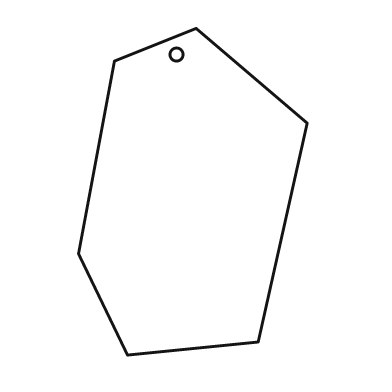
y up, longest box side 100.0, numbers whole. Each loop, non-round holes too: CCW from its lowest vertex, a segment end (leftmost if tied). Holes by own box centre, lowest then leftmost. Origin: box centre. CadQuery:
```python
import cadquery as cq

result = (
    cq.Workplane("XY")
    .moveTo(-20.0, -50.0)
    .lineTo(20.0, -46.0)
    .lineTo(35.0, 21.0)
    .lineTo(1.0, 50.0)
    .lineTo(-24.0, 40.0)
    .lineTo(-35.0, -19.0)
    .close()
    .moveTo(-5.0, 42.0)
    .circle(2.0)
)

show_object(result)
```